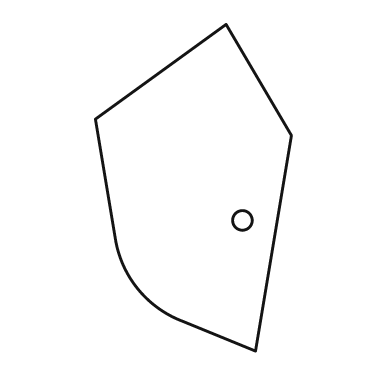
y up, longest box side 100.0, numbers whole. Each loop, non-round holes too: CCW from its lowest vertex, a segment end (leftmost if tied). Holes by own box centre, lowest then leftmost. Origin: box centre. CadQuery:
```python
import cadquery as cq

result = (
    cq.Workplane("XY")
    .moveTo(19.0, -50.0)
    .lineTo(30.0, 16.0)
    .lineTo(10.0, 50.0)
    .lineTo(-30.0, 21.0)
    .lineTo(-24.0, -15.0)
    .threePointArc((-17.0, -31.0), (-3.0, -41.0))
    .close()
    .moveTo(15.0, -10.0)
    .circle(3.0)
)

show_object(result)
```